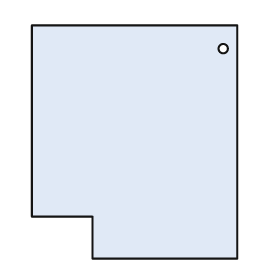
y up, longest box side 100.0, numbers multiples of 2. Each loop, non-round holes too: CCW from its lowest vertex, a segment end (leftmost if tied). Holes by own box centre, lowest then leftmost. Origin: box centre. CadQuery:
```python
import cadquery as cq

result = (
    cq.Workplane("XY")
    .moveTo(-18.0, -50.0)
    .lineTo(44.0, -50.0)
    .lineTo(44.0, 50.0)
    .lineTo(-44.0, 50.0)
    .lineTo(-44.0, -32.0)
    .lineTo(-18.0, -32.0)
    .close()
    .moveTo(38.0, 40.0)
    .circle(2.0)
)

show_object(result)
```